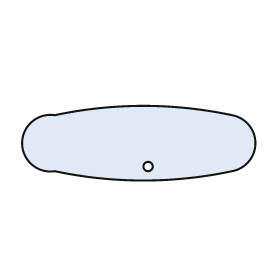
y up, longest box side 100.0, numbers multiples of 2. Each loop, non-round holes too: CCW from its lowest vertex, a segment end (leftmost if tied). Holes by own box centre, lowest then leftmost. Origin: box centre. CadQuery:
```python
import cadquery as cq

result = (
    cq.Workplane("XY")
    .moveTo(-36.0, -12.0)
    .threePointArc((2.0, -16.0), (40.0, -12.0))
    .threePointArc((50.0, 0.0), (40.0, 12.0))
    .threePointArc((2.0, 16.0), (-36.0, 12.0))
    .threePointArc((-50.0, 0.0), (-36.0, -12.0))
    .close()
    .moveTo(4.0, -10.0)
    .circle(2.0)
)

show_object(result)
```